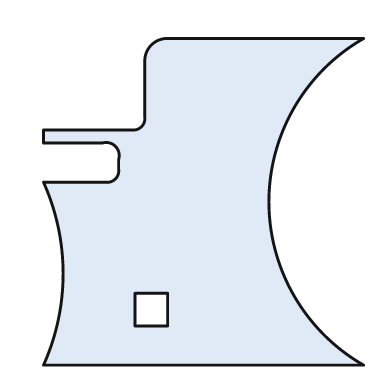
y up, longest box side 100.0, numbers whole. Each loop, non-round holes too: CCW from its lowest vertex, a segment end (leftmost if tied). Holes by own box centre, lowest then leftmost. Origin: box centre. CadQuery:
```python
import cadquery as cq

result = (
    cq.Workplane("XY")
    .moveTo(-49.0, -50.0)
    .lineTo(49.0, -50.0)
    .threePointArc((20.0, 0.0), (49.0, 50.0))
    .lineTo(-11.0, 50.0)
    .threePointArc((-16.0, 48.0), (-18.0, 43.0))
    .lineTo(-18.0, 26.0)
    .threePointArc((-19.0, 23.0), (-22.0, 22.0))
    .lineTo(-49.0, 22.0)
    .lineTo(-49.0, 18.0)
    .lineTo(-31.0, 18.0)
    .threePointArc((-27.0, 17.0), (-26.0, 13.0))
    .lineTo(-26.0, 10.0)
    .threePointArc((-27.0, 7.0), (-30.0, 6.0))
    .lineTo(-49.0, 6.0)
    .threePointArc((-43.0, -22.0), (-49.0, -50.0))
    .close()
    .moveTo(-21.0, -38.0)
    .lineTo(-11.0, -38.0)
    .lineTo(-11.0, -28.0)
    .lineTo(-21.0, -28.0)
    .close()
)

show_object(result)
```